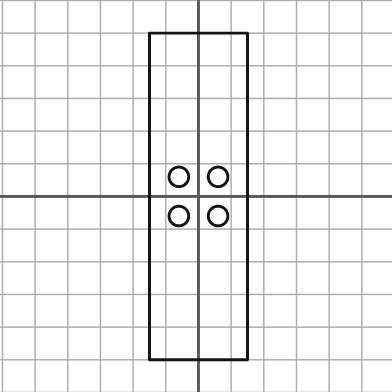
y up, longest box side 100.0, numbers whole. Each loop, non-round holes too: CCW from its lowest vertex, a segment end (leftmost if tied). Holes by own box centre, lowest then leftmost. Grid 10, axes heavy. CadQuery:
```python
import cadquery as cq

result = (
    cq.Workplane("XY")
    .moveTo(-15.0, -50.0)
    .lineTo(15.0, -50.0)
    .lineTo(15.0, 50.0)
    .lineTo(-15.0, 50.0)
    .close()
    .moveTo(-6.0, -6.0)
    .circle(3.0)
    .moveTo(6.0, -6.0)
    .circle(3.0)
    .moveTo(-6.0, 6.0)
    .circle(3.0)
    .moveTo(6.0, 6.0)
    .circle(3.0)
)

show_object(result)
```